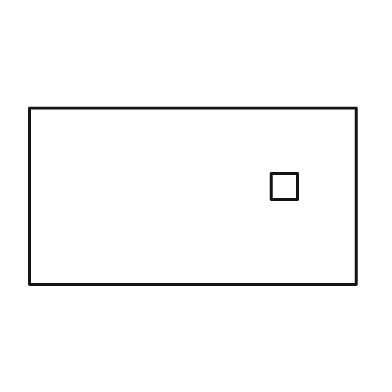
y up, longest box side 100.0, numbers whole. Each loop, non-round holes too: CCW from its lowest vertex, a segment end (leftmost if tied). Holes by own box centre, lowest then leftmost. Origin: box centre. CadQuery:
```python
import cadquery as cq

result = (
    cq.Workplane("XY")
    .moveTo(-50.0, -27.0)
    .lineTo(50.0, -27.0)
    .lineTo(50.0, 27.0)
    .lineTo(-50.0, 27.0)
    .close()
    .moveTo(24.0, -1.0)
    .lineTo(32.0, -1.0)
    .lineTo(32.0, 7.0)
    .lineTo(24.0, 7.0)
    .close()
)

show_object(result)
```